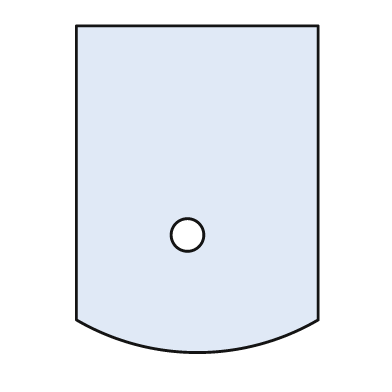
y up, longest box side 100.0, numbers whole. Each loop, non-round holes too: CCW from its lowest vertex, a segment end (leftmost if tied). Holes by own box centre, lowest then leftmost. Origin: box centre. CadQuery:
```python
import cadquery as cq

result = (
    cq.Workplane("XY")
    .moveTo(-37.0, -40.0)
    .threePointArc((0.0, -50.0), (37.0, -40.0))
    .lineTo(37.0, 50.0)
    .lineTo(-37.0, 50.0)
    .close()
    .moveTo(-3.0, -14.0)
    .circle(5.0)
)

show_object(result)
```